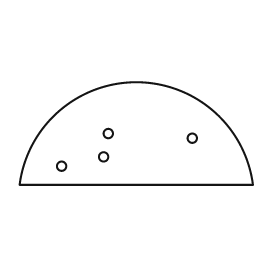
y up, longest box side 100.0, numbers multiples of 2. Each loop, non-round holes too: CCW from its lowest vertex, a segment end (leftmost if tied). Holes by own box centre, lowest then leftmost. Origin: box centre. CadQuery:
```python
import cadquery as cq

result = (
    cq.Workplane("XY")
    .moveTo(-50.0, -22.0)
    .lineTo(50.0, -22.0)
    .threePointArc((0.0, 22.0), (-50.0, -22.0))
    .close()
    .moveTo(-32.0, -14.0)
    .circle(2.0)
    .moveTo(-14.0, -10.0)
    .circle(2.0)
    .moveTo(24.0, -2.0)
    .circle(2.0)
    .moveTo(-12.0, 0.0)
    .circle(2.0)
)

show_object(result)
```